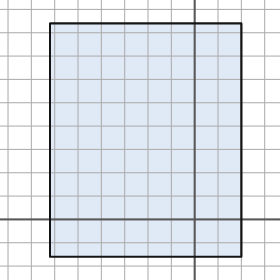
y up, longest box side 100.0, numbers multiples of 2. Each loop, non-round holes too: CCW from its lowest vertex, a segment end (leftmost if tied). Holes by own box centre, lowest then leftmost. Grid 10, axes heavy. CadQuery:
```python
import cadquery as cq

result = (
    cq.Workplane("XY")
    .moveTo(-62.0, -16.0)
    .lineTo(20.0, -16.0)
    .lineTo(20.0, 84.0)
    .lineTo(-62.0, 84.0)
    .close()
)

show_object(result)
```